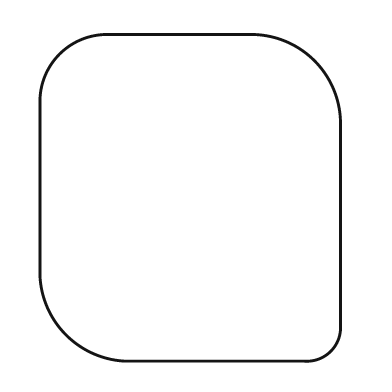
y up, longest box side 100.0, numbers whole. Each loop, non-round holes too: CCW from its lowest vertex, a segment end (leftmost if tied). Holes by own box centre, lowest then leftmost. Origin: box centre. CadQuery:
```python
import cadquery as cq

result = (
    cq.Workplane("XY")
    .moveTo(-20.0, -50.0)
    .lineTo(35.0, -50.0)
    .threePointArc((43.0, -47.0), (46.0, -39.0))
    .lineTo(46.0, 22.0)
    .threePointArc((38.0, 42.0), (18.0, 50.0))
    .lineTo(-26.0, 50.0)
    .threePointArc((-40.0, 44.0), (-46.0, 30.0))
    .lineTo(-46.0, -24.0)
    .threePointArc((-38.0, -42.0), (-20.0, -50.0))
    .close()
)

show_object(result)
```